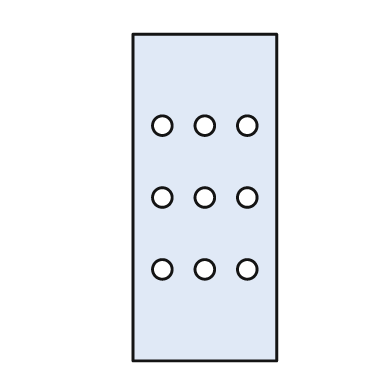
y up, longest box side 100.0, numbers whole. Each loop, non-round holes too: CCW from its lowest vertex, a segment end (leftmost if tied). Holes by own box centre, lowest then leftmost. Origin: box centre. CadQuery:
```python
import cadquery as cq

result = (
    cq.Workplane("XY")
    .moveTo(-22.0, -50.0)
    .lineTo(22.0, -50.0)
    .lineTo(22.0, 50.0)
    .lineTo(-22.0, 50.0)
    .close()
    .moveTo(-13.0, -22.0)
    .circle(3.0)
    .moveTo(0.0, -22.0)
    .circle(3.0)
    .moveTo(13.0, -22.0)
    .circle(3.0)
    .moveTo(-13.0, 0.0)
    .circle(3.0)
    .moveTo(0.0, 0.0)
    .circle(3.0)
    .moveTo(13.0, 0.0)
    .circle(3.0)
    .moveTo(-13.0, 22.0)
    .circle(3.0)
    .moveTo(0.0, 22.0)
    .circle(3.0)
    .moveTo(13.0, 22.0)
    .circle(3.0)
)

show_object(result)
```